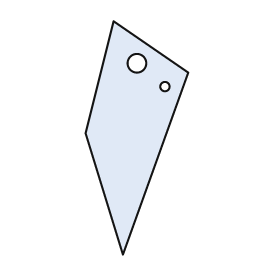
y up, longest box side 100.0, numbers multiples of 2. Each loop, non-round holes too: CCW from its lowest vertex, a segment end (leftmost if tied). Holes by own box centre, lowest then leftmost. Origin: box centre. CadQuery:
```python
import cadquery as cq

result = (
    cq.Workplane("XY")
    .moveTo(-6.0, -50.0)
    .lineTo(22.0, 28.0)
    .lineTo(-10.0, 50.0)
    .lineTo(-22.0, 2.0)
    .close()
    .moveTo(12.0, 22.0)
    .circle(2.0)
    .moveTo(0.0, 32.0)
    .circle(4.0)
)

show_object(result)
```